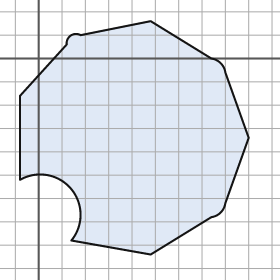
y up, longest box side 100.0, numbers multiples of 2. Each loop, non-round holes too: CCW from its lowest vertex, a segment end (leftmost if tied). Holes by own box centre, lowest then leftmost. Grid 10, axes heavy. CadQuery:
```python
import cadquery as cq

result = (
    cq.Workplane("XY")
    .moveTo(48.0, -84.0)
    .lineTo(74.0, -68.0)
    .threePointArc((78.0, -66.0), (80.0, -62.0))
    .lineTo(90.0, -34.0)
    .lineTo(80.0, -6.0)
    .threePointArc((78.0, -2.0), (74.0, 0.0))
    .lineTo(48.0, 16.0)
    .lineTo(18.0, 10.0)
    .threePointArc((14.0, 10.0), (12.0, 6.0))
    .lineTo(-8.0, -16.0)
    .lineTo(-8.0, -52.0)
    .threePointArc((14.0, -56.0), (14.0, -78.0))
    .close()
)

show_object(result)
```